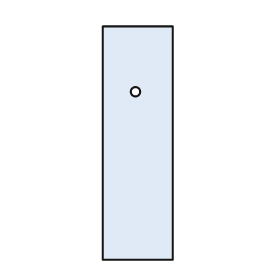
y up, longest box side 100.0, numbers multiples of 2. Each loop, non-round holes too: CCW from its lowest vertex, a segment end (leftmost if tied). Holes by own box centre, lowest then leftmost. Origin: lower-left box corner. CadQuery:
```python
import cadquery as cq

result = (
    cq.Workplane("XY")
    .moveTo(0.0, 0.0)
    .lineTo(30.0, 0.0)
    .lineTo(30.0, 100.0)
    .lineTo(0.0, 100.0)
    .close()
    .moveTo(14.0, 72.0)
    .circle(2.0)
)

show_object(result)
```